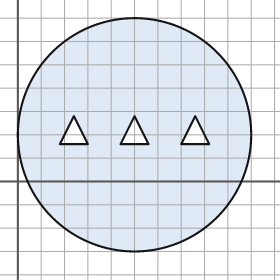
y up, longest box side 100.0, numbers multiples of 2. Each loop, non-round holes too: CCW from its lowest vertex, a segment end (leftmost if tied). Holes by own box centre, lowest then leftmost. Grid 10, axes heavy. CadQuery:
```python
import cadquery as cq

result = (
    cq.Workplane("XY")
    .moveTo(50.0, 20.0)
    .circle(50.0)
    .moveTo(18.0, 16.0)
    .lineTo(30.0, 16.0)
    .lineTo(24.0, 28.0)
    .close()
    .moveTo(44.0, 16.0)
    .lineTo(56.0, 16.0)
    .lineTo(50.0, 28.0)
    .close()
    .moveTo(70.0, 16.0)
    .lineTo(82.0, 16.0)
    .lineTo(76.0, 28.0)
    .close()
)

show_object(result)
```